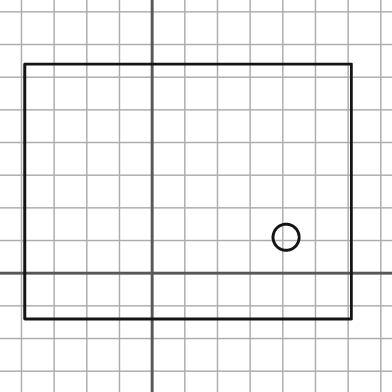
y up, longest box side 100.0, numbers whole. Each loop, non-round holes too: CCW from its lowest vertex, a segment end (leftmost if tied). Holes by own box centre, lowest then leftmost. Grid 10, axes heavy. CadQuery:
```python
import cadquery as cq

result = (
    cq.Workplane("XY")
    .moveTo(-39.0, -14.0)
    .lineTo(61.0, -14.0)
    .lineTo(61.0, 64.0)
    .lineTo(-39.0, 64.0)
    .close()
    .moveTo(41.0, 11.0)
    .circle(4.0)
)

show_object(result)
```